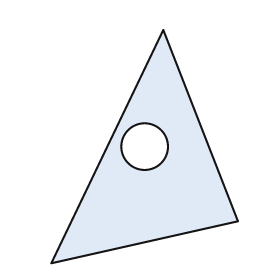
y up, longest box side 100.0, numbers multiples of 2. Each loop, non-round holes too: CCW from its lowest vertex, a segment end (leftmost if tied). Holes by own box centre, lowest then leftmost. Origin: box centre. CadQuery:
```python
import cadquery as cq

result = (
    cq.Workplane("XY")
    .moveTo(-40.0, -50.0)
    .lineTo(40.0, -32.0)
    .lineTo(8.0, 50.0)
    .close()
    .moveTo(0.0, 0.0)
    .circle(10.0)
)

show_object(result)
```